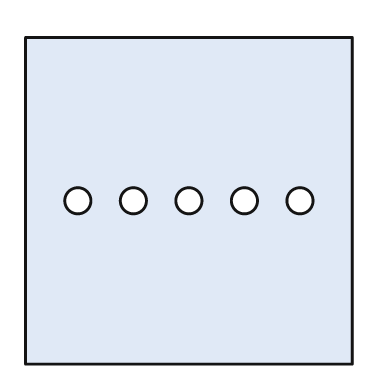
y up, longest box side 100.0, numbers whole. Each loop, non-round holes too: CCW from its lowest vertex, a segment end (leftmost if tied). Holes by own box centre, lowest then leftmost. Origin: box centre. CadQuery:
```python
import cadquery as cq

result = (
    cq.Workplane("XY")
    .moveTo(-50.0, -50.0)
    .lineTo(50.0, -50.0)
    .lineTo(50.0, 50.0)
    .lineTo(-50.0, 50.0)
    .close()
    .moveTo(-34.0, 0.0)
    .circle(4.0)
    .moveTo(-17.0, 0.0)
    .circle(4.0)
    .moveTo(0.0, 0.0)
    .circle(4.0)
    .moveTo(17.0, 0.0)
    .circle(4.0)
    .moveTo(34.0, 0.0)
    .circle(4.0)
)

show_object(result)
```